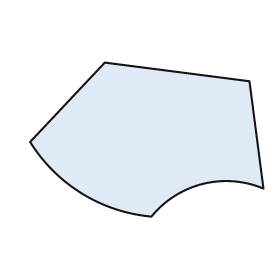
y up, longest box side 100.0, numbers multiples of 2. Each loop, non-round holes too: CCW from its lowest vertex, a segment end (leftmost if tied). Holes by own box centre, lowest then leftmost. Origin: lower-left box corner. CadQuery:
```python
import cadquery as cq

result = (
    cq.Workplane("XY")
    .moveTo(52.0, 0.0)
    .threePointArc((74.0, 14.0), (100.0, 12.0))
    .lineTo(94.0, 58.0)
    .lineTo(32.0, 66.0)
    .lineTo(0.0, 32.0)
    .threePointArc((22.0, 10.0), (52.0, 0.0))
    .close()
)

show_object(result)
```